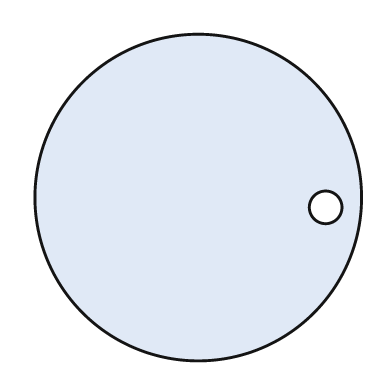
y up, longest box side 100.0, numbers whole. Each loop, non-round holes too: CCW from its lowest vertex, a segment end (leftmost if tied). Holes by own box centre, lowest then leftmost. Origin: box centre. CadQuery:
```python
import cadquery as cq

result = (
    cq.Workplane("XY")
    .moveTo(0.0, 0.0)
    .circle(50.0)
    .moveTo(39.0, -3.0)
    .circle(5.0)
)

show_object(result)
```